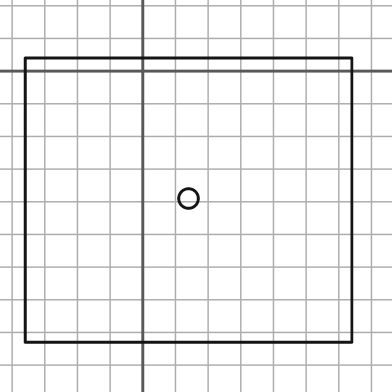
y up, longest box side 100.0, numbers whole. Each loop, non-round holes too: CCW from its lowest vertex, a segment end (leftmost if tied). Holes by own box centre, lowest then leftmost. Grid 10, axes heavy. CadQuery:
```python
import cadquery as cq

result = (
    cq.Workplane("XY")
    .moveTo(-36.0, -83.0)
    .lineTo(64.0, -83.0)
    .lineTo(64.0, 4.0)
    .lineTo(-36.0, 4.0)
    .close()
    .moveTo(14.0, -39.0)
    .circle(3.0)
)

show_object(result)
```